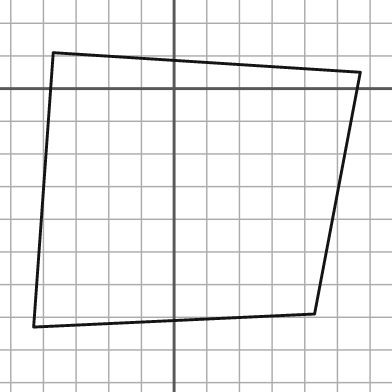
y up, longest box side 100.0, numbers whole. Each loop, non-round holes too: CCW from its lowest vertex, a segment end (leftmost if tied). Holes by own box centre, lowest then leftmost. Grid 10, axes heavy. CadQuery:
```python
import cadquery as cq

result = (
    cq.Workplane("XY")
    .moveTo(-43.0, -73.0)
    .lineTo(43.0, -69.0)
    .lineTo(57.0, 5.0)
    .lineTo(-37.0, 11.0)
    .close()
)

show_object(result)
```